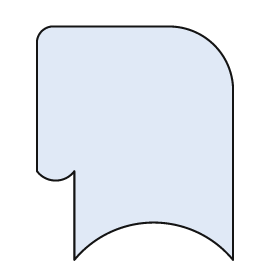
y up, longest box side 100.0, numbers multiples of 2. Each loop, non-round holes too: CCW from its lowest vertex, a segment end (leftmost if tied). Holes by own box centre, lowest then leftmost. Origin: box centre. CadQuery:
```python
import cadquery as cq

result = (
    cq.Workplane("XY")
    .moveTo(-26.0, -50.0)
    .threePointArc((8.0, -34.0), (42.0, -50.0))
    .lineTo(42.0, 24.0)
    .threePointArc((34.0, 42.0), (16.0, 50.0))
    .lineTo(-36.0, 50.0)
    .threePointArc((-40.0, 48.0), (-42.0, 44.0))
    .lineTo(-42.0, -12.0)
    .threePointArc((-34.0, -16.0), (-26.0, -12.0))
    .close()
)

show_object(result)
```